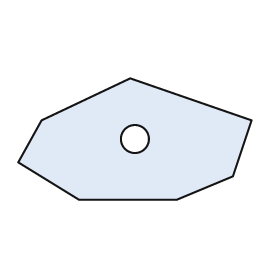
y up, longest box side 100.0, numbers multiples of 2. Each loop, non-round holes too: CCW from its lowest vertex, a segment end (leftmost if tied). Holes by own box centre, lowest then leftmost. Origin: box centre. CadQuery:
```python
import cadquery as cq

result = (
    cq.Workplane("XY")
    .moveTo(-24.0, -26.0)
    .lineTo(18.0, -26.0)
    .lineTo(42.0, -16.0)
    .lineTo(50.0, 8.0)
    .lineTo(-2.0, 26.0)
    .lineTo(-40.0, 8.0)
    .lineTo(-50.0, -10.0)
    .close()
    .moveTo(0.0, 0.0)
    .circle(6.0)
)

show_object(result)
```